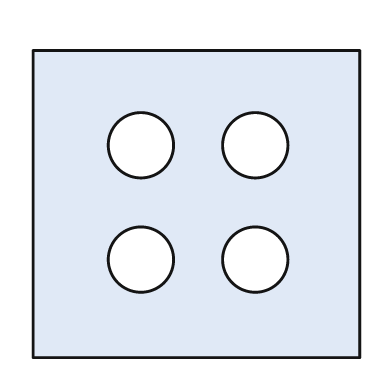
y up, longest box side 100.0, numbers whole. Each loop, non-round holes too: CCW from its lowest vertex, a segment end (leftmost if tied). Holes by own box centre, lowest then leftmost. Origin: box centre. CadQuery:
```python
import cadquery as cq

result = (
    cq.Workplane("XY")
    .moveTo(-50.0, -47.0)
    .lineTo(50.0, -47.0)
    .lineTo(50.0, 47.0)
    .lineTo(-50.0, 47.0)
    .close()
    .moveTo(-17.0, -17.0)
    .circle(10.0)
    .moveTo(18.0, -17.0)
    .circle(10.0)
    .moveTo(-17.0, 18.0)
    .circle(10.0)
    .moveTo(18.0, 18.0)
    .circle(10.0)
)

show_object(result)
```